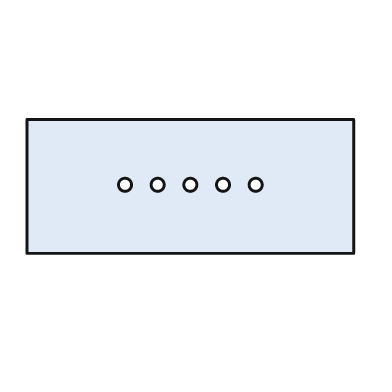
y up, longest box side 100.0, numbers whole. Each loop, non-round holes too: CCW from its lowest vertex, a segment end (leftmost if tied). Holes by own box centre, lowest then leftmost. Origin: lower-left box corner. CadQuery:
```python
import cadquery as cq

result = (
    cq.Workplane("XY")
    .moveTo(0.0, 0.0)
    .lineTo(100.0, 0.0)
    .lineTo(100.0, 41.0)
    .lineTo(0.0, 41.0)
    .close()
    .moveTo(30.0, 21.0)
    .circle(2.0)
    .moveTo(40.0, 21.0)
    .circle(2.0)
    .moveTo(50.0, 21.0)
    .circle(2.0)
    .moveTo(60.0, 21.0)
    .circle(2.0)
    .moveTo(70.0, 21.0)
    .circle(2.0)
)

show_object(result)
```